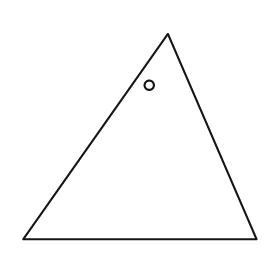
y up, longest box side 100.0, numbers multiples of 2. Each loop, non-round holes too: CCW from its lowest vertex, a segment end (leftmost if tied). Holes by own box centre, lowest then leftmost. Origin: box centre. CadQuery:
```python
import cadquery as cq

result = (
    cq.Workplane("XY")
    .moveTo(-50.0, -44.0)
    .lineTo(50.0, -44.0)
    .lineTo(12.0, 44.0)
    .close()
    .moveTo(4.0, 22.0)
    .circle(2.0)
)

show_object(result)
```